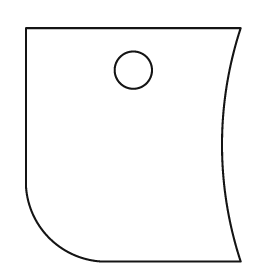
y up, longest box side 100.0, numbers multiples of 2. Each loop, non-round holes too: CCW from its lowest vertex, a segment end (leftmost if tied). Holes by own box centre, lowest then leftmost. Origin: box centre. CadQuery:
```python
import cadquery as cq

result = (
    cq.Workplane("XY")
    .moveTo(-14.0, -50.0)
    .lineTo(46.0, -50.0)
    .threePointArc((38.0, 0.0), (46.0, 50.0))
    .lineTo(-46.0, 50.0)
    .lineTo(-46.0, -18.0)
    .threePointArc((-36.0, -40.0), (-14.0, -50.0))
    .close()
    .moveTo(0.0, 32.0)
    .circle(8.0)
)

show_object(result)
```